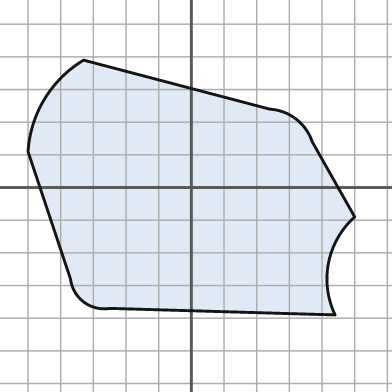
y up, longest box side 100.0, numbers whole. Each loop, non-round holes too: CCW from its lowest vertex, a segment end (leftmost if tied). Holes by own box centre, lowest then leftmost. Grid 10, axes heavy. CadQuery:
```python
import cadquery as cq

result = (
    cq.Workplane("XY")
    .moveTo(44.0, -39.0)
    .threePointArc((42.0, -23.0), (50.0, -9.0))
    .lineTo(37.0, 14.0)
    .threePointArc((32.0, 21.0), (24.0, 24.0))
    .lineTo(-33.0, 39.0)
    .threePointArc((-45.0, 27.0), (-50.0, 11.0))
    .lineTo(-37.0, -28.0)
    .threePointArc((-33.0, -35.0), (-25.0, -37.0))
    .close()
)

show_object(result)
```